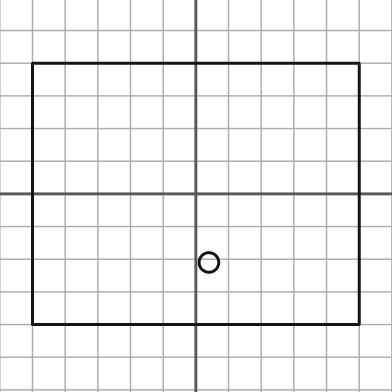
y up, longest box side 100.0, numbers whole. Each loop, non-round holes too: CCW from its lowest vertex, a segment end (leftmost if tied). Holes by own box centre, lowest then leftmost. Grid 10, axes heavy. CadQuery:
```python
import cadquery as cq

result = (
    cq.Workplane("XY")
    .moveTo(-50.0, -40.0)
    .lineTo(50.0, -40.0)
    .lineTo(50.0, 40.0)
    .lineTo(-50.0, 40.0)
    .close()
    .moveTo(4.0, -21.0)
    .circle(3.0)
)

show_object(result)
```